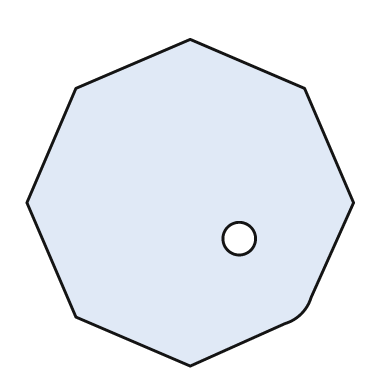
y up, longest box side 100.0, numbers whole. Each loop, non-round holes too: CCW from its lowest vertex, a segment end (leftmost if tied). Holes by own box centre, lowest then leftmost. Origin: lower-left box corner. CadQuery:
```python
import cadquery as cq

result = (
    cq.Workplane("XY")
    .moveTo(50.0, 0.0)
    .lineTo(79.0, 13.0)
    .threePointArc((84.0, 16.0), (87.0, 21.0))
    .lineTo(100.0, 50.0)
    .lineTo(85.0, 85.0)
    .lineTo(50.0, 100.0)
    .lineTo(15.0, 85.0)
    .lineTo(0.0, 50.0)
    .lineTo(15.0, 15.0)
    .close()
    .moveTo(65.0, 39.0)
    .circle(5.0)
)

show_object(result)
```